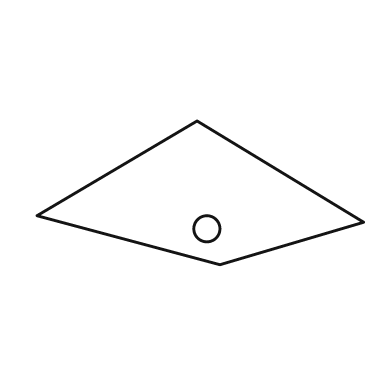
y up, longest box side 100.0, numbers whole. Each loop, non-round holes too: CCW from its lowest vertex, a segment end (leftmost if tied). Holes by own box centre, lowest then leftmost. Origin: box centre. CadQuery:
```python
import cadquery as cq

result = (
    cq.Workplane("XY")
    .moveTo(6.0, -22.0)
    .lineTo(50.0, -9.0)
    .lineTo(-1.0, 22.0)
    .lineTo(-50.0, -7.0)
    .close()
    .moveTo(2.0, -11.0)
    .circle(4.0)
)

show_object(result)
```